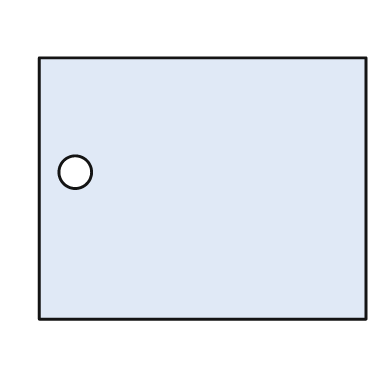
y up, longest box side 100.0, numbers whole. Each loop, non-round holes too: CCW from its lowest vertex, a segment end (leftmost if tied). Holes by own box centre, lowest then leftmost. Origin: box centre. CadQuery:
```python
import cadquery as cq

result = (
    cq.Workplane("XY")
    .moveTo(-50.0, -40.0)
    .lineTo(50.0, -40.0)
    .lineTo(50.0, 40.0)
    .lineTo(-50.0, 40.0)
    .close()
    .moveTo(-39.0, 5.0)
    .circle(5.0)
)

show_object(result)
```